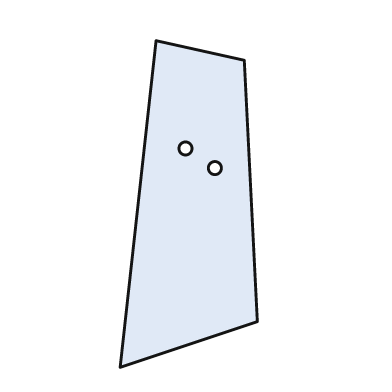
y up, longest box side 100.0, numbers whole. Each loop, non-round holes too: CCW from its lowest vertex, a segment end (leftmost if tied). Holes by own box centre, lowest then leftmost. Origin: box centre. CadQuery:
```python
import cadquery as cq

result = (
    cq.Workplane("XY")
    .moveTo(-21.0, -50.0)
    .lineTo(21.0, -36.0)
    .lineTo(17.0, 44.0)
    .lineTo(-10.0, 50.0)
    .close()
    .moveTo(8.0, 11.0)
    .circle(2.0)
    .moveTo(-1.0, 17.0)
    .circle(2.0)
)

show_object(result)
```